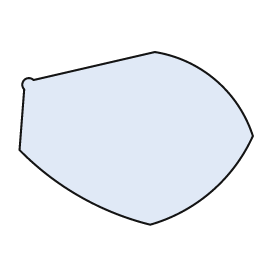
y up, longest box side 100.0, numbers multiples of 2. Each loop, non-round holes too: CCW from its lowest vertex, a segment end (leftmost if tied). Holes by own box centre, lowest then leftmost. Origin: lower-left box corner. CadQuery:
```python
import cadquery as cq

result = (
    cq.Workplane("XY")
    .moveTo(56.0, 0.0)
    .threePointArc((82.0, 14.0), (100.0, 38.0))
    .threePointArc((84.0, 62.0), (58.0, 74.0))
    .lineTo(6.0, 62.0)
    .threePointArc((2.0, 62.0), (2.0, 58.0))
    .lineTo(0.0, 32.0)
    .threePointArc((26.0, 12.0), (56.0, 0.0))
    .close()
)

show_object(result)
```